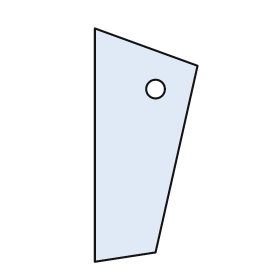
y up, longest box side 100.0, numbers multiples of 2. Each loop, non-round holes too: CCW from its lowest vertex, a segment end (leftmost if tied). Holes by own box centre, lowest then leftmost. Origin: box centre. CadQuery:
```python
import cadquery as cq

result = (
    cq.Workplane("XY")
    .moveTo(-22.0, -50.0)
    .lineTo(4.0, -46.0)
    .lineTo(22.0, 34.0)
    .lineTo(-22.0, 50.0)
    .close()
    .moveTo(4.0, 24.0)
    .circle(4.0)
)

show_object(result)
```